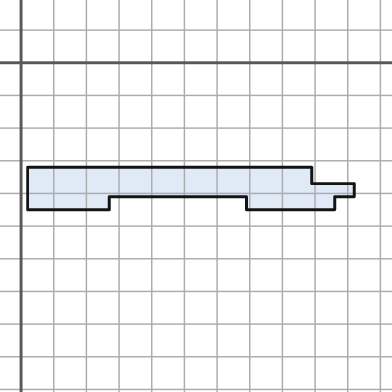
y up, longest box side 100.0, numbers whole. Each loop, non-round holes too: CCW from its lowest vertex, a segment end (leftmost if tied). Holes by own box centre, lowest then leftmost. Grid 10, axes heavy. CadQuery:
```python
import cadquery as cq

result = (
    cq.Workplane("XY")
    .moveTo(2.0, -45.0)
    .lineTo(27.0, -45.0)
    .lineTo(27.0, -41.0)
    .lineTo(69.0, -41.0)
    .lineTo(69.0, -45.0)
    .lineTo(96.0, -45.0)
    .lineTo(96.0, -41.0)
    .lineTo(102.0, -41.0)
    .lineTo(102.0, -37.0)
    .lineTo(89.0, -37.0)
    .lineTo(89.0, -32.0)
    .lineTo(2.0, -32.0)
    .close()
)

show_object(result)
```